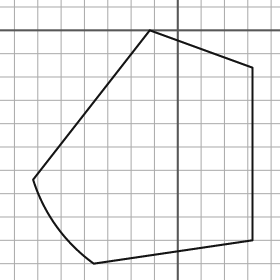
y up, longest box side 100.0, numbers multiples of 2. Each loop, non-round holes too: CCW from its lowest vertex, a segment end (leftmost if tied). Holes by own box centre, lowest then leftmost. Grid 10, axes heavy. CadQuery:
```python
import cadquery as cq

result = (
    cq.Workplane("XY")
    .moveTo(-36.0, -100.0)
    .lineTo(32.0, -90.0)
    .lineTo(32.0, -16.0)
    .lineTo(-12.0, 0.0)
    .lineTo(-62.0, -64.0)
    .threePointArc((-52.0, -84.0), (-36.0, -100.0))
    .close()
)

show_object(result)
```